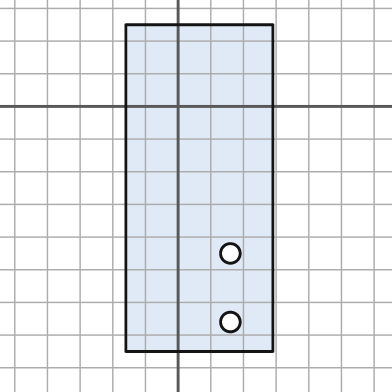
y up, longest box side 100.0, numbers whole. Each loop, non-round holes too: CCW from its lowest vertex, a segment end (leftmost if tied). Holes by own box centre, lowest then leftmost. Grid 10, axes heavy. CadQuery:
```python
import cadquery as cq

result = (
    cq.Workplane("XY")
    .moveTo(-16.0, -75.0)
    .lineTo(29.0, -75.0)
    .lineTo(29.0, 25.0)
    .lineTo(-16.0, 25.0)
    .close()
    .moveTo(16.0, -66.0)
    .circle(3.0)
    .moveTo(16.0, -45.0)
    .circle(3.0)
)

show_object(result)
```